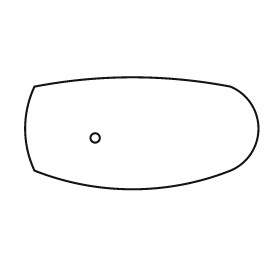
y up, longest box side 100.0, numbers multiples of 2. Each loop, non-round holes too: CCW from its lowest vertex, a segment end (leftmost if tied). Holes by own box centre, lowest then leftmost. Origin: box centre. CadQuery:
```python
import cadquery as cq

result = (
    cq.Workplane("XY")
    .moveTo(-46.0, -16.0)
    .threePointArc((-4.0, -24.0), (38.0, -16.0))
    .threePointArc((50.0, 2.0), (38.0, 20.0))
    .threePointArc((-4.0, 24.0), (-46.0, 20.0))
    .threePointArc((-50.0, 2.0), (-46.0, -16.0))
    .close()
    .moveTo(-20.0, -2.0)
    .circle(2.0)
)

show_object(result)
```